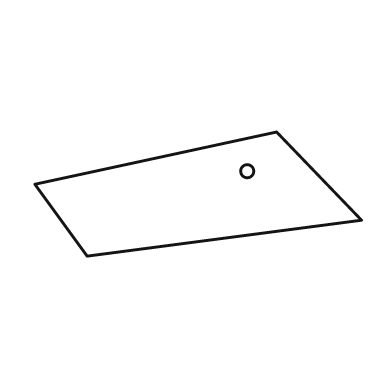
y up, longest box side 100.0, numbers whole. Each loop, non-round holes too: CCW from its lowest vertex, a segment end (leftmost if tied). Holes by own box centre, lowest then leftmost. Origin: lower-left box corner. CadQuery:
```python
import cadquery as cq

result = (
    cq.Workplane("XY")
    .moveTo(16.0, 0.0)
    .lineTo(100.0, 11.0)
    .lineTo(74.0, 38.0)
    .lineTo(0.0, 22.0)
    .close()
    .moveTo(65.0, 26.0)
    .circle(2.0)
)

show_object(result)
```